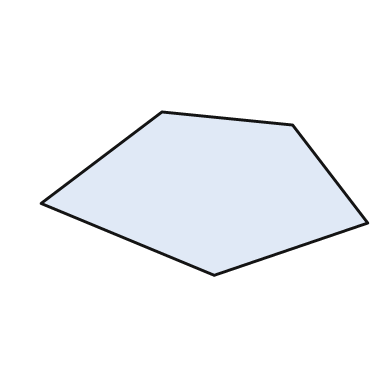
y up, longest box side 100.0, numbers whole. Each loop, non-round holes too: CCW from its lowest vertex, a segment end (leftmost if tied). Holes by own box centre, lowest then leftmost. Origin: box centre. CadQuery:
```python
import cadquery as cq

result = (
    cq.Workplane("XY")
    .moveTo(3.0, -25.0)
    .lineTo(50.0, -9.0)
    .lineTo(27.0, 21.0)
    .lineTo(-13.0, 25.0)
    .lineTo(-50.0, -3.0)
    .close()
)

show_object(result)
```